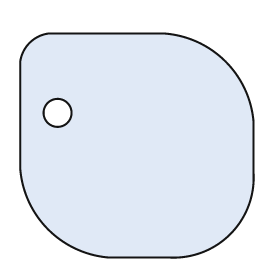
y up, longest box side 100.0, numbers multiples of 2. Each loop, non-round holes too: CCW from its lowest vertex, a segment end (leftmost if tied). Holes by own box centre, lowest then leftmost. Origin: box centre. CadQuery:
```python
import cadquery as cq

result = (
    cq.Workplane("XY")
    .moveTo(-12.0, -48.0)
    .lineTo(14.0, -48.0)
    .threePointArc((40.0, -38.0), (50.0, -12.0))
    .lineTo(50.0, 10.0)
    .threePointArc((38.0, 36.0), (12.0, 48.0))
    .lineTo(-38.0, 48.0)
    .threePointArc((-46.0, 44.0), (-50.0, 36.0))
    .lineTo(-50.0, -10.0)
    .threePointArc((-38.0, -36.0), (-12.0, -48.0))
    .close()
    .moveTo(-34.0, 14.0)
    .circle(6.0)
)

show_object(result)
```